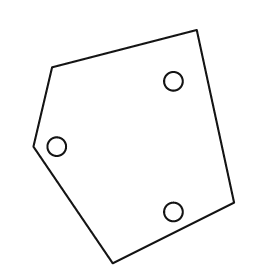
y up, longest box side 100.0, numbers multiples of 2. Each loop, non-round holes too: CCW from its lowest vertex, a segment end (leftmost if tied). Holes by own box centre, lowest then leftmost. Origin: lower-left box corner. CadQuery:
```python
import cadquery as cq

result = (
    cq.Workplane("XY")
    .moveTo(34.0, 0.0)
    .lineTo(86.0, 26.0)
    .lineTo(70.0, 100.0)
    .lineTo(8.0, 84.0)
    .lineTo(0.0, 50.0)
    .close()
    .moveTo(60.0, 22.0)
    .circle(4.0)
    .moveTo(10.0, 50.0)
    .circle(4.0)
    .moveTo(60.0, 78.0)
    .circle(4.0)
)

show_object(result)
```